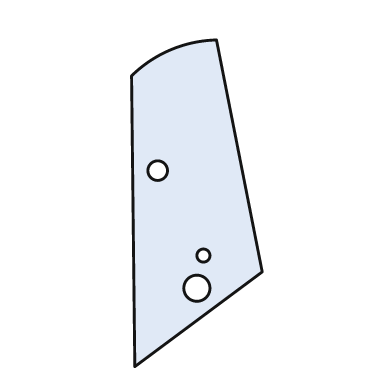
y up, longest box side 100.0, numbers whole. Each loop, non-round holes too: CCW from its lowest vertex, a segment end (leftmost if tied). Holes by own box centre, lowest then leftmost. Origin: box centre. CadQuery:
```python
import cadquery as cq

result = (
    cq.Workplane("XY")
    .moveTo(-19.0, -50.0)
    .lineTo(20.0, -21.0)
    .lineTo(6.0, 50.0)
    .threePointArc((-8.0, 47.0), (-20.0, 39.0))
    .close()
    .moveTo(0.0, -26.0)
    .circle(4.0)
    .moveTo(2.0, -16.0)
    .circle(2.0)
    .moveTo(-12.0, 10.0)
    .circle(3.0)
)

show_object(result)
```